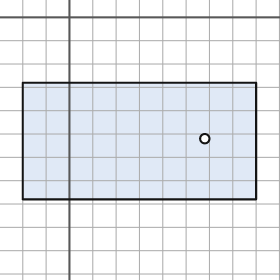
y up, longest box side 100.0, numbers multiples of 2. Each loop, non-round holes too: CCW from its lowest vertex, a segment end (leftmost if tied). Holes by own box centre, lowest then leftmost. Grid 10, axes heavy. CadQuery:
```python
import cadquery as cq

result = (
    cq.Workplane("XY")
    .moveTo(-20.0, -78.0)
    .lineTo(80.0, -78.0)
    .lineTo(80.0, -28.0)
    .lineTo(-20.0, -28.0)
    .close()
    .moveTo(58.0, -52.0)
    .circle(2.0)
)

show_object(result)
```